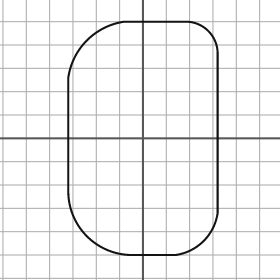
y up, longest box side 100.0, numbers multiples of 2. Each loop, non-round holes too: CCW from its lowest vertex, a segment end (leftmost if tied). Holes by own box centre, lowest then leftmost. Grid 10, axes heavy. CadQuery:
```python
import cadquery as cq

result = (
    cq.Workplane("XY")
    .moveTo(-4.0, -50.0)
    .lineTo(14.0, -50.0)
    .threePointArc((26.0, -44.0), (32.0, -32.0))
    .lineTo(32.0, 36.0)
    .threePointArc((28.0, 46.0), (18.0, 50.0))
    .lineTo(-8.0, 50.0)
    .threePointArc((-24.0, 42.0), (-32.0, 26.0))
    .lineTo(-32.0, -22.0)
    .threePointArc((-24.0, -42.0), (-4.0, -50.0))
    .close()
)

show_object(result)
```